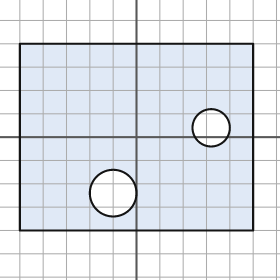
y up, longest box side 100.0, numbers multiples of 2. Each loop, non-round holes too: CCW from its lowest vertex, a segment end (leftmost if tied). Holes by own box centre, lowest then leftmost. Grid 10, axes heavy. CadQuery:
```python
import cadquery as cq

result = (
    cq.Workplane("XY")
    .moveTo(-50.0, -40.0)
    .lineTo(50.0, -40.0)
    .lineTo(50.0, 40.0)
    .lineTo(-50.0, 40.0)
    .close()
    .moveTo(-10.0, -24.0)
    .circle(10.0)
    .moveTo(32.0, 4.0)
    .circle(8.0)
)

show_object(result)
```